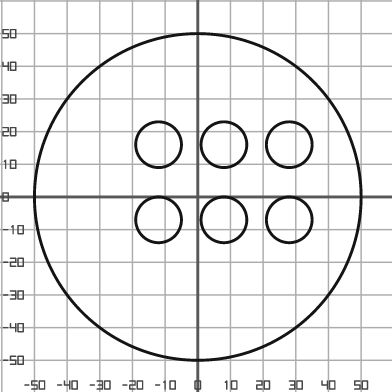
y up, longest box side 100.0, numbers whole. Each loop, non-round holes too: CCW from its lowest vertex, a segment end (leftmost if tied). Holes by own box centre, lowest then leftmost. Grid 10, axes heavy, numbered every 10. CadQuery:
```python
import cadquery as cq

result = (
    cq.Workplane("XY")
    .moveTo(0.0, 0.0)
    .circle(50.0)
    .moveTo(-12.0, -7.0)
    .circle(7.0)
    .moveTo(8.0, -7.0)
    .circle(7.0)
    .moveTo(28.0, -7.0)
    .circle(7.0)
    .moveTo(-12.0, 16.0)
    .circle(7.0)
    .moveTo(8.0, 16.0)
    .circle(7.0)
    .moveTo(28.0, 16.0)
    .circle(7.0)
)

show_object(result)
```